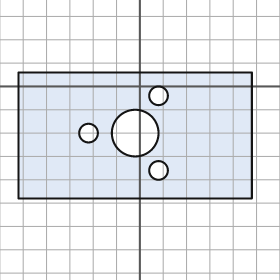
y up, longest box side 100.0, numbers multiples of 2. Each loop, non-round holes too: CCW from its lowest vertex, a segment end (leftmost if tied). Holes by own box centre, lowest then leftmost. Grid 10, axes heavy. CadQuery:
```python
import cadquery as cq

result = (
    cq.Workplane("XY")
    .moveTo(-52.0, -48.0)
    .lineTo(48.0, -48.0)
    .lineTo(48.0, 6.0)
    .lineTo(-52.0, 6.0)
    .close()
    .moveTo(8.0, -36.0)
    .circle(4.0)
    .moveTo(-22.0, -20.0)
    .circle(4.0)
    .moveTo(-2.0, -20.0)
    .circle(10.0)
    .moveTo(8.0, -4.0)
    .circle(4.0)
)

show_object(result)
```